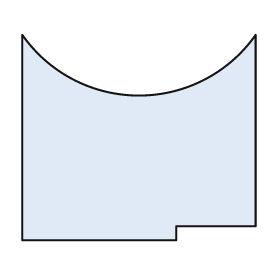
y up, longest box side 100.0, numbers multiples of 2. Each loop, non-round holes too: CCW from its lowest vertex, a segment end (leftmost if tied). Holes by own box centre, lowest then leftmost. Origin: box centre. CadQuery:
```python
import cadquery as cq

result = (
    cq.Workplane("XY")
    .moveTo(-50.0, -44.0)
    .lineTo(16.0, -44.0)
    .lineTo(16.0, -38.0)
    .lineTo(50.0, -38.0)
    .lineTo(50.0, 44.0)
    .threePointArc((0.0, 18.0), (-50.0, 44.0))
    .close()
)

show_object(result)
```